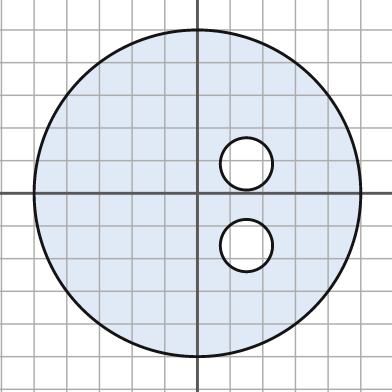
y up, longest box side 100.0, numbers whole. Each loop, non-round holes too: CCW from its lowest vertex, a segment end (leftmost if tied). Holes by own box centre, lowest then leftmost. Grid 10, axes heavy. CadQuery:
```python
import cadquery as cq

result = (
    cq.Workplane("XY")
    .moveTo(0.0, 0.0)
    .circle(50.0)
    .moveTo(15.0, -16.0)
    .circle(8.0)
    .moveTo(15.0, 9.0)
    .circle(8.0)
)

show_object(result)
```